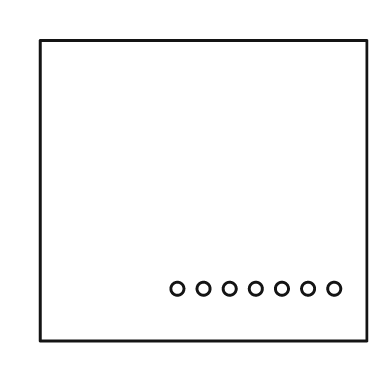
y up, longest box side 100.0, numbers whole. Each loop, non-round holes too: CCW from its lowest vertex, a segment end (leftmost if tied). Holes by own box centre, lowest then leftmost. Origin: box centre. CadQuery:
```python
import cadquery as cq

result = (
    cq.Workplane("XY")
    .moveTo(-50.0, -46.0)
    .lineTo(50.0, -46.0)
    .lineTo(50.0, 46.0)
    .lineTo(-50.0, 46.0)
    .close()
    .moveTo(-8.0, -30.0)
    .circle(2.0)
    .moveTo(0.0, -30.0)
    .circle(2.0)
    .moveTo(8.0, -30.0)
    .circle(2.0)
    .moveTo(16.0, -30.0)
    .circle(2.0)
    .moveTo(24.0, -30.0)
    .circle(2.0)
    .moveTo(32.0, -30.0)
    .circle(2.0)
    .moveTo(40.0, -30.0)
    .circle(2.0)
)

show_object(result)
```